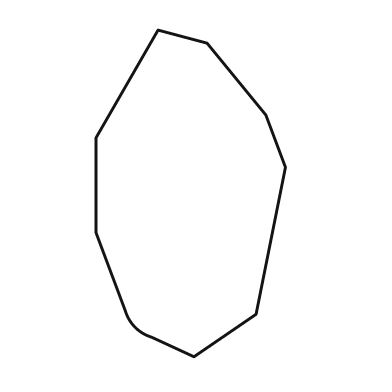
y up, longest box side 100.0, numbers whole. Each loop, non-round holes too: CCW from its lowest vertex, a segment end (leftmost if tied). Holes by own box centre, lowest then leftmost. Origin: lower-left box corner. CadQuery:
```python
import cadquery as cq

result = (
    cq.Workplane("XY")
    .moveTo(30.0, 0.0)
    .lineTo(49.0, 13.0)
    .lineTo(58.0, 58.0)
    .lineTo(52.0, 74.0)
    .lineTo(34.0, 96.0)
    .lineTo(19.0, 100.0)
    .lineTo(0.0, 67.0)
    .lineTo(0.0, 38.0)
    .lineTo(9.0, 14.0)
    .threePointArc((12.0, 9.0), (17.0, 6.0))
    .close()
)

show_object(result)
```